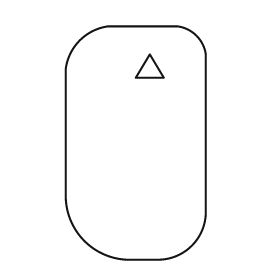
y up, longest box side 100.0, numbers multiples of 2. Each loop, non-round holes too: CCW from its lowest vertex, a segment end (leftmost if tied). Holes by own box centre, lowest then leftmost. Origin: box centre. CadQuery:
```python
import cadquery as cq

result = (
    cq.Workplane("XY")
    .moveTo(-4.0, -50.0)
    .lineTo(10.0, -50.0)
    .threePointArc((24.0, -44.0), (30.0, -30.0))
    .lineTo(30.0, 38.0)
    .threePointArc((26.0, 46.0), (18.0, 50.0))
    .lineTo(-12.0, 50.0)
    .threePointArc((-24.0, 44.0), (-30.0, 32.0))
    .lineTo(-30.0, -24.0)
    .threePointArc((-22.0, -42.0), (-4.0, -50.0))
    .close()
    .moveTo(0.0, 28.0)
    .lineTo(12.0, 28.0)
    .lineTo(6.0, 38.0)
    .close()
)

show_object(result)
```